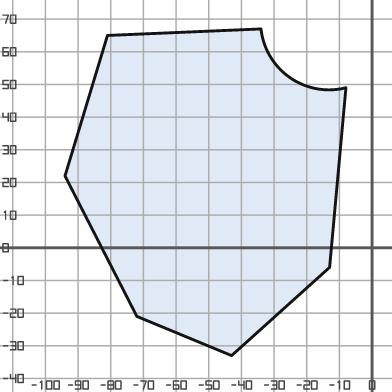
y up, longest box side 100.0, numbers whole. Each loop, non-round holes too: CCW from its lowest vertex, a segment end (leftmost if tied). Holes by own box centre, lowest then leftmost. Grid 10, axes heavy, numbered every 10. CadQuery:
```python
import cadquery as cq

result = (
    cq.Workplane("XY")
    .moveTo(-43.0, -33.0)
    .lineTo(-13.0, -6.0)
    .lineTo(-8.0, 49.0)
    .threePointArc((-25.0, 52.0), (-34.0, 67.0))
    .lineTo(-81.0, 65.0)
    .lineTo(-94.0, 22.0)
    .lineTo(-72.0, -21.0)
    .close()
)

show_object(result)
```